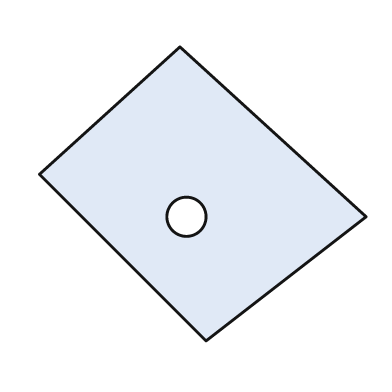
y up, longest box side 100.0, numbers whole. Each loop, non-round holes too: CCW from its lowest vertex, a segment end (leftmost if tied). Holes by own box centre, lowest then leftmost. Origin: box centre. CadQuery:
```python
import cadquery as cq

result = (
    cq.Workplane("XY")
    .moveTo(1.0, -45.0)
    .lineTo(50.0, -7.0)
    .lineTo(-7.0, 45.0)
    .lineTo(-50.0, 6.0)
    .close()
    .moveTo(-5.0, -7.0)
    .circle(6.0)
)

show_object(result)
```